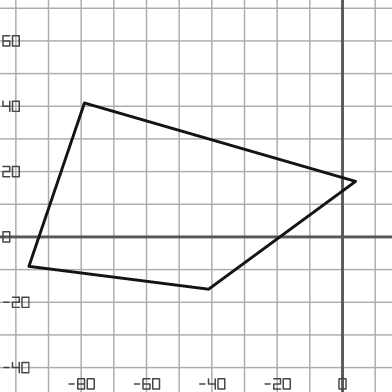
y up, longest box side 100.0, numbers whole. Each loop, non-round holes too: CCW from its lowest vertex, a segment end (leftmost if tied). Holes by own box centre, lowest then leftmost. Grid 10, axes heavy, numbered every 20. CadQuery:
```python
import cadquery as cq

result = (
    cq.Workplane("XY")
    .moveTo(-41.0, -16.0)
    .lineTo(4.0, 17.0)
    .lineTo(-79.0, 41.0)
    .lineTo(-96.0, -9.0)
    .close()
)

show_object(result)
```